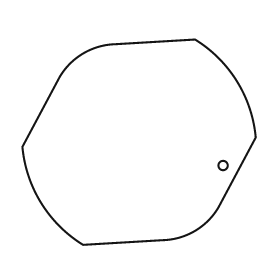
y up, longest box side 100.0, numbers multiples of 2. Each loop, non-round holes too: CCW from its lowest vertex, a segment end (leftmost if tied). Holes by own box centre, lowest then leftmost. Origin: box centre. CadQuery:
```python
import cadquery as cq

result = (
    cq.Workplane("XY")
    .moveTo(-24.0, -44.0)
    .lineTo(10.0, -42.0)
    .threePointArc((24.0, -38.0), (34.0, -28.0))
    .lineTo(50.0, 2.0)
    .threePointArc((42.0, 26.0), (24.0, 44.0))
    .lineTo(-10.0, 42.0)
    .threePointArc((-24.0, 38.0), (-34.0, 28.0))
    .lineTo(-50.0, -2.0)
    .threePointArc((-42.0, -26.0), (-24.0, -44.0))
    .close()
    .moveTo(36.0, -10.0)
    .circle(2.0)
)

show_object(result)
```